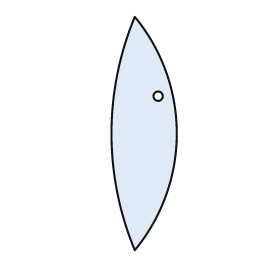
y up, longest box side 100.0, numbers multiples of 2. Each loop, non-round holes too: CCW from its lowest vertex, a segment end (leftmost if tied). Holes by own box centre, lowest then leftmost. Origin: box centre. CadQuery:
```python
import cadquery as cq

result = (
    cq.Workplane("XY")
    .moveTo(-4.0, -50.0)
    .threePointArc((14.0, 0.0), (-4.0, 50.0))
    .threePointArc((-14.0, 0.0), (-4.0, -50.0))
    .close()
    .moveTo(6.0, 16.0)
    .circle(2.0)
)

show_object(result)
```